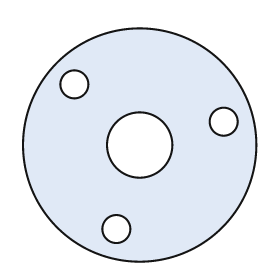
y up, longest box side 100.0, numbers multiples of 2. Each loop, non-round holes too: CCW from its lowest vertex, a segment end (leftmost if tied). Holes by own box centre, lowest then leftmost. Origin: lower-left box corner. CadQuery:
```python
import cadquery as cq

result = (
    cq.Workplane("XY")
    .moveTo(50.0, 50.0)
    .circle(50.0)
    .moveTo(40.0, 14.0)
    .circle(6.0)
    .moveTo(50.0, 50.0)
    .circle(14.0)
    .moveTo(86.0, 60.0)
    .circle(6.0)
    .moveTo(22.0, 76.0)
    .circle(6.0)
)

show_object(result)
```